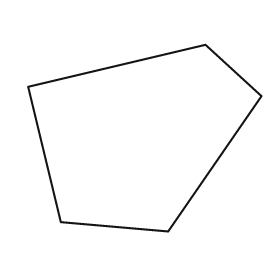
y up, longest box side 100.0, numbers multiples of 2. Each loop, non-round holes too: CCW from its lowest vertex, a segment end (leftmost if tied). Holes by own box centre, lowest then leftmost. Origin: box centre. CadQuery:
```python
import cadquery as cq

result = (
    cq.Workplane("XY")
    .moveTo(10.0, -40.0)
    .lineTo(50.0, 18.0)
    .lineTo(26.0, 40.0)
    .lineTo(-50.0, 22.0)
    .lineTo(-36.0, -36.0)
    .close()
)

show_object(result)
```